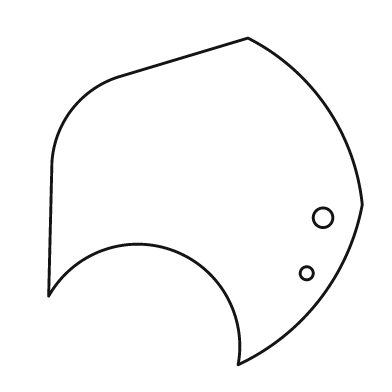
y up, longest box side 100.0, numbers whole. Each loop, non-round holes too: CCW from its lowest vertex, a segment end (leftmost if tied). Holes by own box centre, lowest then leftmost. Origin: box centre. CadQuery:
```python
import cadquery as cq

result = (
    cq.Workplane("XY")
    .moveTo(10.0, -50.0)
    .threePointArc((35.0, -30.0), (48.0, -1.0))
    .threePointArc((37.0, 29.0), (13.0, 50.0))
    .lineTo(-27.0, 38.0)
    .threePointArc((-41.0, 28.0), (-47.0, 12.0))
    .lineTo(-48.0, -29.0)
    .threePointArc((-10.0, -15.0), (10.0, -50.0))
    .close()
    .moveTo(31.0, -22.0)
    .circle(2.0)
    .moveTo(36.0, -5.0)
    .circle(3.0)
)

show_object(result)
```